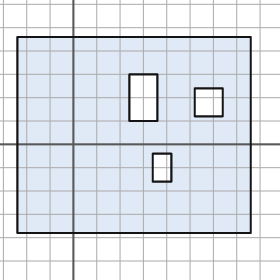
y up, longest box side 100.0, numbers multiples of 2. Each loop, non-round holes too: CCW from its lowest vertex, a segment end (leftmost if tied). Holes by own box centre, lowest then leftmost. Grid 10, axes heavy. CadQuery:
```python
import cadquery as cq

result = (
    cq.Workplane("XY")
    .moveTo(-24.0, -38.0)
    .lineTo(76.0, -38.0)
    .lineTo(76.0, 46.0)
    .lineTo(-24.0, 46.0)
    .close()
    .moveTo(34.0, -16.0)
    .lineTo(42.0, -16.0)
    .lineTo(42.0, -4.0)
    .lineTo(34.0, -4.0)
    .close()
    .moveTo(52.0, 12.0)
    .lineTo(64.0, 12.0)
    .lineTo(64.0, 24.0)
    .lineTo(52.0, 24.0)
    .close()
    .moveTo(24.0, 10.0)
    .lineTo(36.0, 10.0)
    .lineTo(36.0, 30.0)
    .lineTo(24.0, 30.0)
    .close()
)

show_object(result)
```